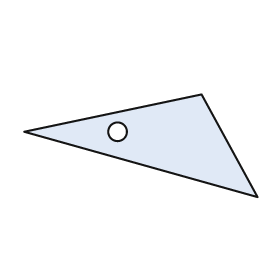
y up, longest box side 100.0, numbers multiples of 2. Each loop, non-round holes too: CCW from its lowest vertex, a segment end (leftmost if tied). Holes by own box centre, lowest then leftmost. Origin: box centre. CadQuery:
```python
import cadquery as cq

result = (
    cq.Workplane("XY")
    .moveTo(50.0, -22.0)
    .lineTo(26.0, 22.0)
    .lineTo(-50.0, 6.0)
    .close()
    .moveTo(-10.0, 6.0)
    .circle(4.0)
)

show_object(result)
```